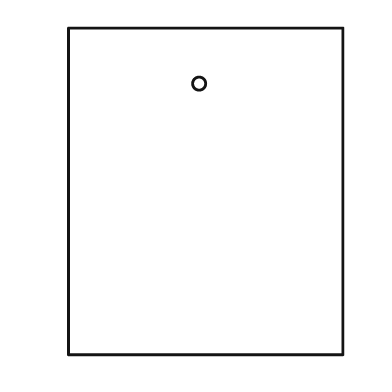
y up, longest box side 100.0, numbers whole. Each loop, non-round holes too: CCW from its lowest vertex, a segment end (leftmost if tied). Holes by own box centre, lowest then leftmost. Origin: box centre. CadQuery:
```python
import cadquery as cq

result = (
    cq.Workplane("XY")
    .moveTo(-42.0, -50.0)
    .lineTo(42.0, -50.0)
    .lineTo(42.0, 50.0)
    .lineTo(-42.0, 50.0)
    .close()
    .moveTo(-2.0, 33.0)
    .circle(2.0)
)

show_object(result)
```